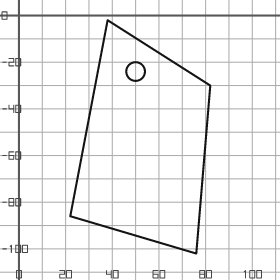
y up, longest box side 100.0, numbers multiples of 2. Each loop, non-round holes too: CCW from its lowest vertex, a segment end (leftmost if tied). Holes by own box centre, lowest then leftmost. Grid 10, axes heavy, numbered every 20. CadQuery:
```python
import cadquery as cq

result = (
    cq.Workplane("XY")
    .moveTo(76.0, -102.0)
    .lineTo(82.0, -30.0)
    .lineTo(38.0, -2.0)
    .lineTo(22.0, -86.0)
    .close()
    .moveTo(50.0, -24.0)
    .circle(4.0)
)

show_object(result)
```